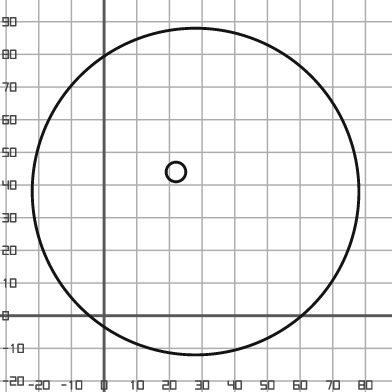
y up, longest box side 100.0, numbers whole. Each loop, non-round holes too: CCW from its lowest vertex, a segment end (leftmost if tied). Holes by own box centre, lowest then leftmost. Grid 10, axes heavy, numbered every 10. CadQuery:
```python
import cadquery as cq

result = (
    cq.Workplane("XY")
    .moveTo(28.0, 38.0)
    .circle(50.0)
    .moveTo(22.0, 44.0)
    .circle(3.0)
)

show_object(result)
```